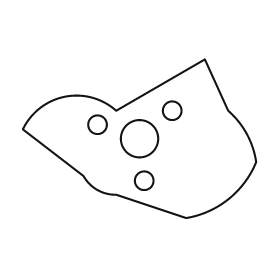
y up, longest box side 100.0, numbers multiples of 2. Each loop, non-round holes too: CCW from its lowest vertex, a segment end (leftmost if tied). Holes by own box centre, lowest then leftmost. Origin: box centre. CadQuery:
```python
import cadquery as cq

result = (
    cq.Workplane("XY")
    .moveTo(20.0, -34.0)
    .threePointArc((38.0, -26.0), (50.0, -10.0))
    .threePointArc((46.0, 2.0), (38.0, 12.0))
    .lineTo(28.0, 34.0)
    .lineTo(-10.0, 12.0)
    .threePointArc((-32.0, 18.0), (-50.0, 4.0))
    .lineTo(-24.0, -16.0)
    .threePointArc((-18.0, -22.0), (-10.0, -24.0))
    .close()
    .moveTo(2.0, -18.0)
    .circle(4.0)
    .moveTo(0.0, 0.0)
    .circle(8.0)
    .moveTo(-18.0, 6.0)
    .circle(4.0)
    .moveTo(14.0, 12.0)
    .circle(4.0)
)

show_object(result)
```